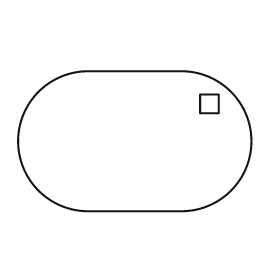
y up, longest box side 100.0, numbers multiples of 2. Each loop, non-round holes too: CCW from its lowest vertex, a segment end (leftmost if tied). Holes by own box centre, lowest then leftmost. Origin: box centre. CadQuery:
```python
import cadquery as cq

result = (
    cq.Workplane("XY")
    .moveTo(-20.0, -30.0)
    .lineTo(20.0, -30.0)
    .threePointArc((50.0, 0.0), (20.0, 30.0))
    .lineTo(-20.0, 30.0)
    .threePointArc((-50.0, 0.0), (-20.0, -30.0))
    .close()
    .moveTo(28.0, 12.0)
    .lineTo(36.0, 12.0)
    .lineTo(36.0, 20.0)
    .lineTo(28.0, 20.0)
    .close()
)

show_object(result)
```